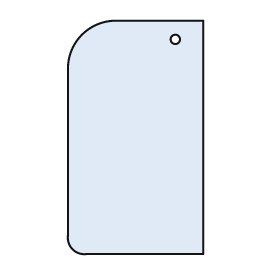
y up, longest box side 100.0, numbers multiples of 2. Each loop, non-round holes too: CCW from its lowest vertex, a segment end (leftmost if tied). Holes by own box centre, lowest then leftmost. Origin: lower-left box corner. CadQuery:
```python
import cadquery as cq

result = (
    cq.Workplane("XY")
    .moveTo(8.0, 0.0)
    .lineTo(58.0, 0.0)
    .lineTo(58.0, 100.0)
    .lineTo(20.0, 100.0)
    .threePointArc((6.0, 94.0), (0.0, 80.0))
    .lineTo(0.0, 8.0)
    .threePointArc((2.0, 2.0), (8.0, 0.0))
    .close()
    .moveTo(46.0, 92.0)
    .circle(2.0)
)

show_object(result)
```